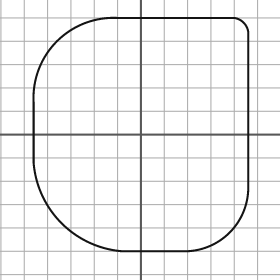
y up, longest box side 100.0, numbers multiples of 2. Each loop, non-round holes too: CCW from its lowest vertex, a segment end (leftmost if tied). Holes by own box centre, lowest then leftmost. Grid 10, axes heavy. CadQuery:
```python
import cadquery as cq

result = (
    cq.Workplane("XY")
    .moveTo(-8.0, -50.0)
    .lineTo(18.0, -50.0)
    .threePointArc((38.0, -42.0), (46.0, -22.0))
    .lineTo(46.0, 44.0)
    .threePointArc((44.0, 48.0), (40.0, 50.0))
    .lineTo(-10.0, 50.0)
    .threePointArc((-36.0, 40.0), (-46.0, 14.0))
    .lineTo(-46.0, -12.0)
    .threePointArc((-34.0, -38.0), (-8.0, -50.0))
    .close()
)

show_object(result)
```